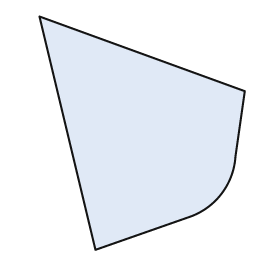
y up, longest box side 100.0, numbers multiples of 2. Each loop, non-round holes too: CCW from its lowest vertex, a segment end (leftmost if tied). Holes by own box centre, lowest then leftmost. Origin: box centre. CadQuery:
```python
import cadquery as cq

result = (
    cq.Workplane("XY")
    .moveTo(-20.0, -50.0)
    .lineTo(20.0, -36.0)
    .threePointArc((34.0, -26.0), (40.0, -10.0))
    .lineTo(44.0, 18.0)
    .lineTo(-44.0, 50.0)
    .close()
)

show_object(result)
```